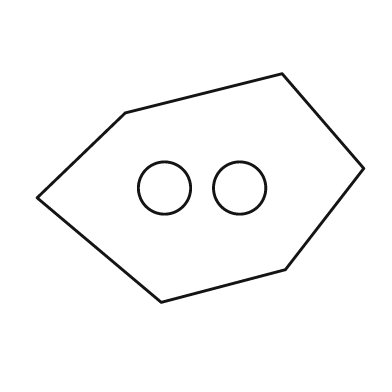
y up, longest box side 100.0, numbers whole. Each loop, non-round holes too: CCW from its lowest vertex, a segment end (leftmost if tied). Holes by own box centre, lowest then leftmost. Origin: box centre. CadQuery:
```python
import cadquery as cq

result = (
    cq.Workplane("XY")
    .moveTo(-12.0, -35.0)
    .lineTo(26.0, -25.0)
    .lineTo(50.0, 6.0)
    .lineTo(25.0, 35.0)
    .lineTo(-23.0, 23.0)
    .lineTo(-50.0, -3.0)
    .close()
    .moveTo(-11.0, 0.0)
    .circle(8.0)
    .moveTo(12.0, 0.0)
    .circle(8.0)
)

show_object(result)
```